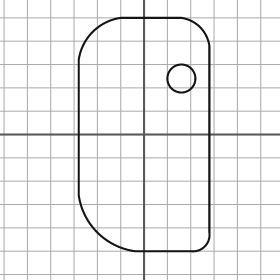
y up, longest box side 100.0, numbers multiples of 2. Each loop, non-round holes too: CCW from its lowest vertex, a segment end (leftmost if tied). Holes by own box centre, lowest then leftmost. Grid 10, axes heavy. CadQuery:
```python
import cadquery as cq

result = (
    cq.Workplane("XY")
    .moveTo(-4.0, -50.0)
    .lineTo(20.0, -50.0)
    .threePointArc((26.0, -48.0), (28.0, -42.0))
    .lineTo(28.0, 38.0)
    .threePointArc((24.0, 46.0), (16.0, 50.0))
    .lineTo(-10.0, 50.0)
    .threePointArc((-22.0, 44.0), (-28.0, 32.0))
    .lineTo(-28.0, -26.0)
    .threePointArc((-20.0, -42.0), (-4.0, -50.0))
    .close()
    .moveTo(16.0, 24.0)
    .circle(6.0)
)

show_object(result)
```